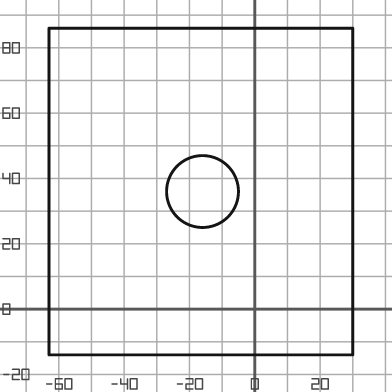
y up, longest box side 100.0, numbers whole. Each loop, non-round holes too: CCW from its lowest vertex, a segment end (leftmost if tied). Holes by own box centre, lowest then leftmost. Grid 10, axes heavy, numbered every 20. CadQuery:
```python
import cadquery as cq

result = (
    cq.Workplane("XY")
    .moveTo(-63.0, -14.0)
    .lineTo(30.0, -14.0)
    .lineTo(30.0, 86.0)
    .lineTo(-63.0, 86.0)
    .close()
    .moveTo(-16.0, 36.0)
    .circle(11.0)
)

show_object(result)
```